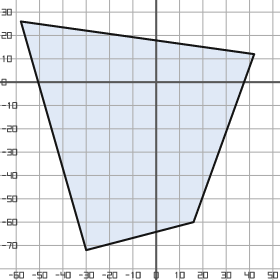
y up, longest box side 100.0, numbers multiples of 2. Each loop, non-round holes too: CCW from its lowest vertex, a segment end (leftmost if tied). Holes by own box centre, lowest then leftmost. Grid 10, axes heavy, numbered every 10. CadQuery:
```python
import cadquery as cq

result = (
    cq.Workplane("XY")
    .moveTo(-30.0, -72.0)
    .lineTo(16.0, -60.0)
    .lineTo(42.0, 12.0)
    .lineTo(-58.0, 26.0)
    .close()
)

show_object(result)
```